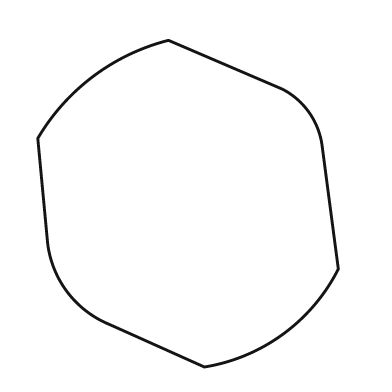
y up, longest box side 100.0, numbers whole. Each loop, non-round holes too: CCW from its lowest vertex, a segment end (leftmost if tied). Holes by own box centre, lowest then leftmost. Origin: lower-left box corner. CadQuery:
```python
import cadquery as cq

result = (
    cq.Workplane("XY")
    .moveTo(51.0, 0.0)
    .threePointArc((75.0, 10.0), (92.0, 30.0))
    .lineTo(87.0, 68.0)
    .threePointArc((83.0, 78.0), (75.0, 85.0))
    .lineTo(40.0, 100.0)
    .threePointArc((17.0, 89.0), (0.0, 70.0))
    .lineTo(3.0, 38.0)
    .threePointArc((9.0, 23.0), (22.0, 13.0))
    .close()
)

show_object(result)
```